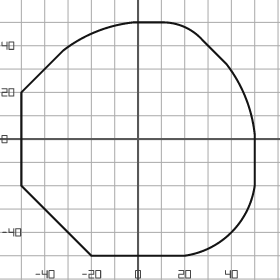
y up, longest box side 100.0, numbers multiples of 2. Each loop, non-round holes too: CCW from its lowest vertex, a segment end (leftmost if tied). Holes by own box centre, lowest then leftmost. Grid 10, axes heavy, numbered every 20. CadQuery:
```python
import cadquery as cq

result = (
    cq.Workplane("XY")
    .moveTo(-20.0, -50.0)
    .lineTo(20.0, -50.0)
    .threePointArc((40.0, -40.0), (50.0, -20.0))
    .lineTo(50.0, 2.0)
    .threePointArc((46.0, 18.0), (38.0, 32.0))
    .lineTo(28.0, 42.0)
    .threePointArc((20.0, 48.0), (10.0, 50.0))
    .lineTo(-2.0, 50.0)
    .threePointArc((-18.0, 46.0), (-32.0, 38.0))
    .lineTo(-50.0, 20.0)
    .lineTo(-50.0, -20.0)
    .close()
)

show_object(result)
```